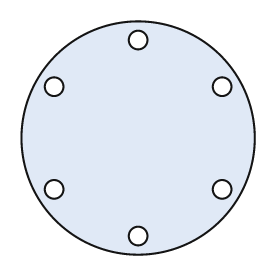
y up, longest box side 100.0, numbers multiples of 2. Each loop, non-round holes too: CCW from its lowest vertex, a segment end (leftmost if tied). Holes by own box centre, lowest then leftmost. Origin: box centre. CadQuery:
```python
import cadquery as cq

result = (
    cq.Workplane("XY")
    .moveTo(0.0, 0.0)
    .circle(50.0)
    .moveTo(0.0, -42.0)
    .circle(4.0)
    .moveTo(-36.0, -22.0)
    .circle(4.0)
    .moveTo(36.0, -22.0)
    .circle(4.0)
    .moveTo(-36.0, 22.0)
    .circle(4.0)
    .moveTo(36.0, 22.0)
    .circle(4.0)
    .moveTo(0.0, 42.0)
    .circle(4.0)
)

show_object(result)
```